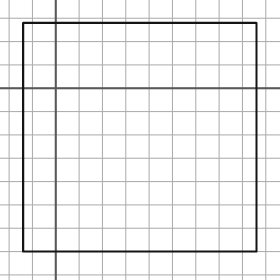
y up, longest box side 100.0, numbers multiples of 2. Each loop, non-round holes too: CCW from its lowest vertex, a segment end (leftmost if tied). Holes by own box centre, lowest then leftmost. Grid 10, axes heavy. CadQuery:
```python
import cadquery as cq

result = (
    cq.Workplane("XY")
    .moveTo(-14.0, -70.0)
    .lineTo(86.0, -70.0)
    .lineTo(86.0, 28.0)
    .lineTo(-14.0, 28.0)
    .close()
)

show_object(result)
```